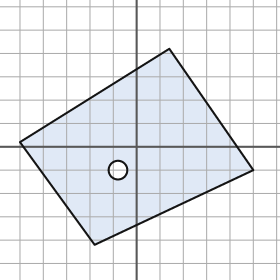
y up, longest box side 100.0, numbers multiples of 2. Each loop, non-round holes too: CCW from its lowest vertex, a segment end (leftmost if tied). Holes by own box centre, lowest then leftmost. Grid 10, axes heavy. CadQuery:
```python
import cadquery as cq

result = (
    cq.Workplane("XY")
    .moveTo(-18.0, -42.0)
    .lineTo(50.0, -10.0)
    .lineTo(14.0, 42.0)
    .lineTo(-50.0, 2.0)
    .close()
    .moveTo(-8.0, -10.0)
    .circle(4.0)
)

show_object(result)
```